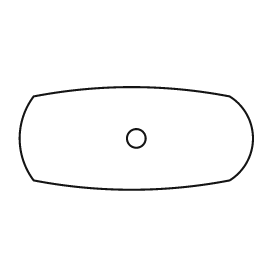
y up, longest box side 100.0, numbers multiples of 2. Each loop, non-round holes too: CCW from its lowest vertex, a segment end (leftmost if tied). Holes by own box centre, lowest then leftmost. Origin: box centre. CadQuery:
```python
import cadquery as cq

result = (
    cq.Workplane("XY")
    .moveTo(-44.0, -18.0)
    .threePointArc((-2.0, -22.0), (40.0, -18.0))
    .threePointArc((50.0, 0.0), (40.0, 18.0))
    .threePointArc((-2.0, 22.0), (-44.0, 18.0))
    .threePointArc((-50.0, 0.0), (-44.0, -18.0))
    .close()
    .moveTo(0.0, 0.0)
    .circle(4.0)
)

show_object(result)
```